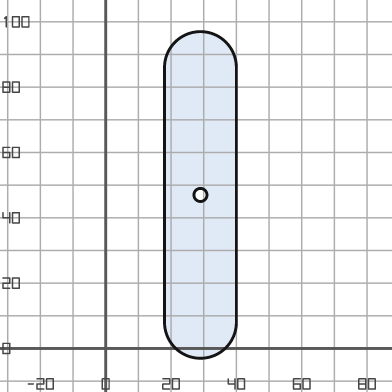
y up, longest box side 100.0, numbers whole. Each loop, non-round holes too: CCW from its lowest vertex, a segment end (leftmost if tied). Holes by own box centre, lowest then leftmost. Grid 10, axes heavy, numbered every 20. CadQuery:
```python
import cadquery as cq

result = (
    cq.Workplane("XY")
    .moveTo(18.0, 8.0)
    .threePointArc((29.0, -3.0), (40.0, 8.0))
    .lineTo(40.0, 86.0)
    .threePointArc((29.0, 97.0), (18.0, 86.0))
    .close()
    .moveTo(29.0, 47.0)
    .circle(2.0)
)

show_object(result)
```